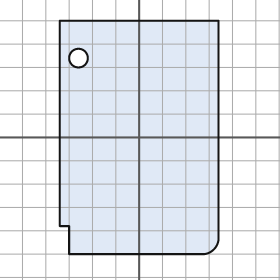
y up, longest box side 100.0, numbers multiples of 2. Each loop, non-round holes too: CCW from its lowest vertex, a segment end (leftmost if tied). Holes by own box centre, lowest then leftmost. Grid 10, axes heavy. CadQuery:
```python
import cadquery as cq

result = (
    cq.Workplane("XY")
    .moveTo(-30.0, -50.0)
    .lineTo(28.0, -50.0)
    .threePointArc((32.0, -48.0), (34.0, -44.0))
    .lineTo(34.0, 50.0)
    .lineTo(-34.0, 50.0)
    .lineTo(-34.0, -38.0)
    .lineTo(-30.0, -38.0)
    .close()
    .moveTo(-26.0, 34.0)
    .circle(4.0)
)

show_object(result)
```